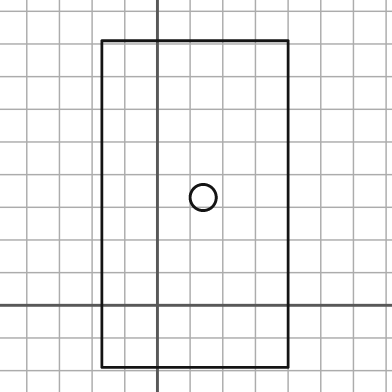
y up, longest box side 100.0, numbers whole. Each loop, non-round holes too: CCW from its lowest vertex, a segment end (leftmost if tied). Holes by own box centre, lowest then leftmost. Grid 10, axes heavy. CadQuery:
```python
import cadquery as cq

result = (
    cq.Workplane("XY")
    .moveTo(-17.0, -19.0)
    .lineTo(40.0, -19.0)
    .lineTo(40.0, 81.0)
    .lineTo(-17.0, 81.0)
    .close()
    .moveTo(14.0, 33.0)
    .circle(4.0)
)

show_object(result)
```